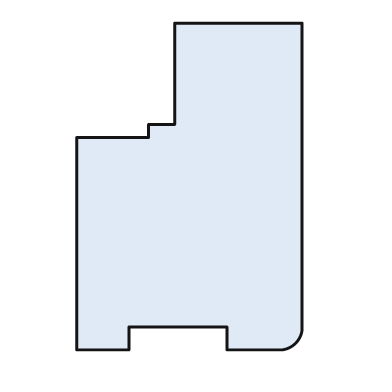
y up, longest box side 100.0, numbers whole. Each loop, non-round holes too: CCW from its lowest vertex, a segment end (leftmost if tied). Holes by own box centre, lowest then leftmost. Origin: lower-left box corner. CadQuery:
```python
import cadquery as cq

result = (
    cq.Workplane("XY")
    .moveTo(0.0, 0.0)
    .lineTo(16.0, 0.0)
    .lineTo(16.0, 7.0)
    .lineTo(46.0, 7.0)
    .lineTo(46.0, 0.0)
    .lineTo(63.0, 0.0)
    .threePointArc((67.0, 2.0), (69.0, 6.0))
    .lineTo(69.0, 100.0)
    .lineTo(30.0, 100.0)
    .lineTo(30.0, 69.0)
    .lineTo(22.0, 69.0)
    .lineTo(22.0, 65.0)
    .lineTo(0.0, 65.0)
    .close()
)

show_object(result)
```